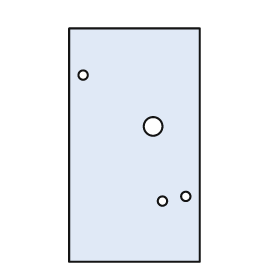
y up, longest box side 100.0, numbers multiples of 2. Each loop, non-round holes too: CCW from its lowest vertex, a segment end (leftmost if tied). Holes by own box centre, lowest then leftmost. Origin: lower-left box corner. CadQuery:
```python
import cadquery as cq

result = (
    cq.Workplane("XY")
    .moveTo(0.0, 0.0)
    .lineTo(56.0, 0.0)
    .lineTo(56.0, 100.0)
    .lineTo(0.0, 100.0)
    .close()
    .moveTo(40.0, 26.0)
    .circle(2.0)
    .moveTo(50.0, 28.0)
    .circle(2.0)
    .moveTo(36.0, 58.0)
    .circle(4.0)
    .moveTo(6.0, 80.0)
    .circle(2.0)
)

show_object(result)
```